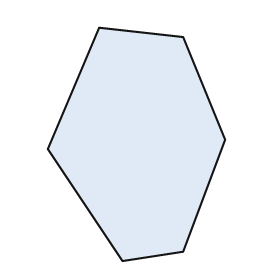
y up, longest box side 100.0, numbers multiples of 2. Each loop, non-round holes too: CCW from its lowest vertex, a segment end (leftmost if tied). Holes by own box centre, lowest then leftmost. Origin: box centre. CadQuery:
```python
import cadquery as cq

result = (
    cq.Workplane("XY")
    .moveTo(-6.0, -50.0)
    .lineTo(20.0, -46.0)
    .lineTo(38.0, 2.0)
    .lineTo(20.0, 46.0)
    .lineTo(-16.0, 50.0)
    .lineTo(-38.0, -2.0)
    .close()
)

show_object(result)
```